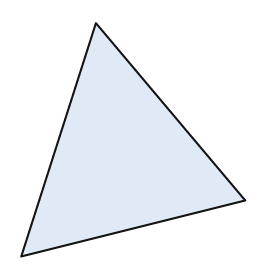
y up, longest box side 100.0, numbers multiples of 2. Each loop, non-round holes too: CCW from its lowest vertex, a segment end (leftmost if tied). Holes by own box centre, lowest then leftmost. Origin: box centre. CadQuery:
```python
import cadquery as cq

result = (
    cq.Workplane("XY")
    .moveTo(-48.0, -50.0)
    .lineTo(48.0, -26.0)
    .lineTo(-16.0, 50.0)
    .close()
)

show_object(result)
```